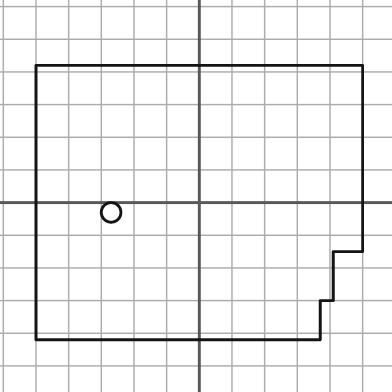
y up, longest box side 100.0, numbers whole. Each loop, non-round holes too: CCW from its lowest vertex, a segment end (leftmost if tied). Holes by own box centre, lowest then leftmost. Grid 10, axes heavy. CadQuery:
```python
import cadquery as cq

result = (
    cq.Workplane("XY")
    .moveTo(-50.0, -42.0)
    .lineTo(37.0, -42.0)
    .lineTo(37.0, -30.0)
    .lineTo(41.0, -30.0)
    .lineTo(41.0, -15.0)
    .lineTo(50.0, -15.0)
    .lineTo(50.0, 42.0)
    .lineTo(-50.0, 42.0)
    .close()
    .moveTo(-27.0, -3.0)
    .circle(3.0)
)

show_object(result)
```